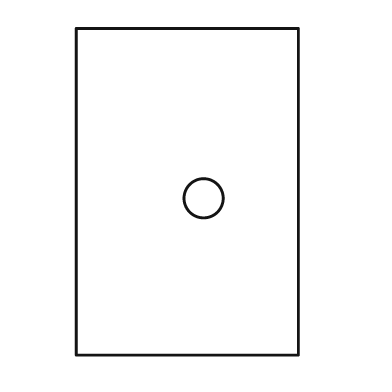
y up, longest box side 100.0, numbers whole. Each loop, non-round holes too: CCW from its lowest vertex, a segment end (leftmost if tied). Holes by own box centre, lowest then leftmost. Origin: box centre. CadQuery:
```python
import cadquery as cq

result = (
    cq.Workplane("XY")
    .moveTo(-34.0, -50.0)
    .lineTo(34.0, -50.0)
    .lineTo(34.0, 50.0)
    .lineTo(-34.0, 50.0)
    .close()
    .moveTo(5.0, -2.0)
    .circle(6.0)
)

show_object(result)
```